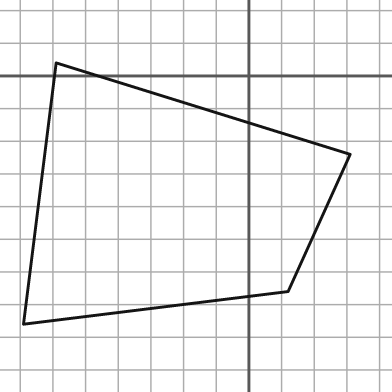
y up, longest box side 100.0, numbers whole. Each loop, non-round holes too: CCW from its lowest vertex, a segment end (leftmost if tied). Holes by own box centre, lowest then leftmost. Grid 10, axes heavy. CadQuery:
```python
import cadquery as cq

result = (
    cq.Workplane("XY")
    .moveTo(-69.0, -76.0)
    .lineTo(12.0, -66.0)
    .lineTo(31.0, -24.0)
    .lineTo(-59.0, 4.0)
    .close()
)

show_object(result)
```